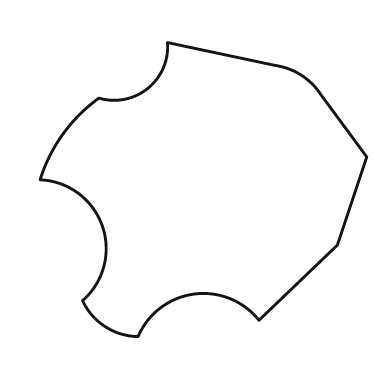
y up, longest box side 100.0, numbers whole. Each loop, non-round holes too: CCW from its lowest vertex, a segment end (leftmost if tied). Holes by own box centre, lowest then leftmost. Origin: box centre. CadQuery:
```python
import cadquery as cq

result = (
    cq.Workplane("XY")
    .moveTo(-20.0, -45.0)
    .threePointArc((-3.0, -32.0), (17.0, -40.0))
    .lineTo(41.0, -17.0)
    .lineTo(50.0, 10.0)
    .lineTo(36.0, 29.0)
    .threePointArc((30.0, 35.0), (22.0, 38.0))
    .lineTo(-11.0, 45.0)
    .threePointArc((-17.0, 31.0), (-32.0, 28.0))
    .threePointArc((-43.0, 17.0), (-50.0, 3.0))
    .threePointArc((-31.0, -11.0), (-37.0, -34.0))
    .threePointArc((-30.0, -42.0), (-20.0, -45.0))
    .close()
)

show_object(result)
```